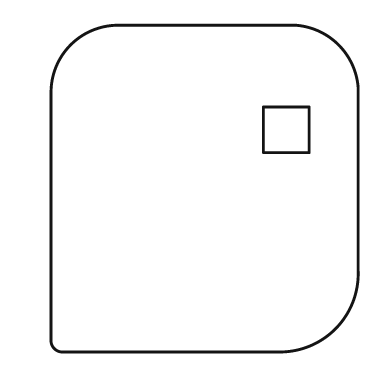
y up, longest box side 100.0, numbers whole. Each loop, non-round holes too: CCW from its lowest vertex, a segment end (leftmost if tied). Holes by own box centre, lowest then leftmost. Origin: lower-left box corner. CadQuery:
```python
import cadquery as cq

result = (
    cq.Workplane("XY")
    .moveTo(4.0, 0.0)
    .lineTo(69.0, 0.0)
    .threePointArc((87.0, 7.0), (94.0, 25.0))
    .lineTo(94.0, 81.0)
    .threePointArc((88.0, 94.0), (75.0, 100.0))
    .lineTo(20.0, 100.0)
    .threePointArc((6.0, 94.0), (0.0, 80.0))
    .lineTo(0.0, 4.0)
    .threePointArc((1.0, 1.0), (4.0, 0.0))
    .close()
    .moveTo(65.0, 61.0)
    .lineTo(79.0, 61.0)
    .lineTo(79.0, 75.0)
    .lineTo(65.0, 75.0)
    .close()
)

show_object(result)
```